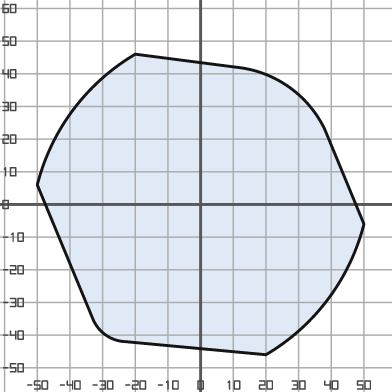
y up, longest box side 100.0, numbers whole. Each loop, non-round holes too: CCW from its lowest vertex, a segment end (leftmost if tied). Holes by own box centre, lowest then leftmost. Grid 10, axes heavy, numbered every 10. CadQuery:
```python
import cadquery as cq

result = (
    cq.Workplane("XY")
    .moveTo(20.0, -46.0)
    .threePointArc((39.0, -29.0), (50.0, -6.0))
    .lineTo(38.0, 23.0)
    .threePointArc((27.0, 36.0), (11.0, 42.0))
    .lineTo(-20.0, 46.0)
    .threePointArc((-39.0, 29.0), (-50.0, 6.0))
    .lineTo(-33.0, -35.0)
    .threePointArc((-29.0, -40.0), (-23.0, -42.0))
    .close()
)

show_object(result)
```